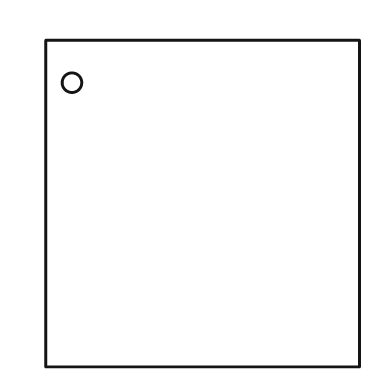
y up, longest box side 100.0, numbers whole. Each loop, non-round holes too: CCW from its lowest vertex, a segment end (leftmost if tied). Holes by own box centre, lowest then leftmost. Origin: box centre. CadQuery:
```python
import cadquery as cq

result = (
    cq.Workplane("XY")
    .moveTo(-48.0, -50.0)
    .lineTo(48.0, -50.0)
    .lineTo(48.0, 50.0)
    .lineTo(-48.0, 50.0)
    .close()
    .moveTo(-40.0, 37.0)
    .circle(3.0)
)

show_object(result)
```